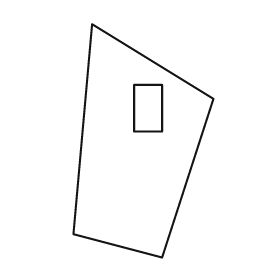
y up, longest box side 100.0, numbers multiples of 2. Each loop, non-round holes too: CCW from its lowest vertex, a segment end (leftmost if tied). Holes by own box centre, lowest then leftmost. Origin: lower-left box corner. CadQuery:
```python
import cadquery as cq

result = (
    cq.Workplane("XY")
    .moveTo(38.0, 0.0)
    .lineTo(60.0, 68.0)
    .lineTo(8.0, 100.0)
    .lineTo(0.0, 10.0)
    .close()
    .moveTo(26.0, 54.0)
    .lineTo(38.0, 54.0)
    .lineTo(38.0, 74.0)
    .lineTo(26.0, 74.0)
    .close()
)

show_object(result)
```